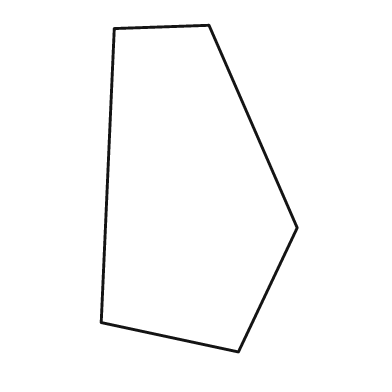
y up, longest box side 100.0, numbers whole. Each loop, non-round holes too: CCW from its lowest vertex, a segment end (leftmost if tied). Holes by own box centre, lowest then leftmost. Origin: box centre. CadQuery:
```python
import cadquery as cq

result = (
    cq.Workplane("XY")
    .moveTo(12.0, -50.0)
    .lineTo(30.0, -12.0)
    .lineTo(3.0, 50.0)
    .lineTo(-26.0, 49.0)
    .lineTo(-30.0, -41.0)
    .close()
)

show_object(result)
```